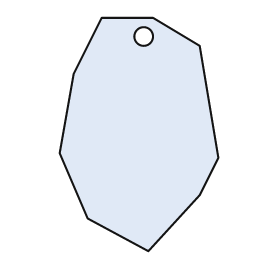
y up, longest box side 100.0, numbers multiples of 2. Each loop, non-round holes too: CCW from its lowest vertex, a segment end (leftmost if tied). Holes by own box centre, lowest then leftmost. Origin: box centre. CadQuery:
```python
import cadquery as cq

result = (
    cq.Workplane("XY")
    .moveTo(4.0, -50.0)
    .lineTo(26.0, -26.0)
    .lineTo(34.0, -10.0)
    .lineTo(26.0, 38.0)
    .lineTo(6.0, 50.0)
    .lineTo(-16.0, 50.0)
    .lineTo(-28.0, 26.0)
    .lineTo(-34.0, -8.0)
    .lineTo(-22.0, -36.0)
    .close()
    .moveTo(2.0, 42.0)
    .circle(4.0)
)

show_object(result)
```